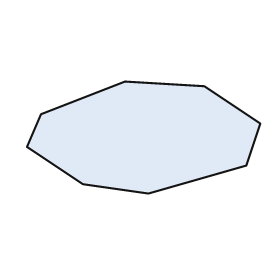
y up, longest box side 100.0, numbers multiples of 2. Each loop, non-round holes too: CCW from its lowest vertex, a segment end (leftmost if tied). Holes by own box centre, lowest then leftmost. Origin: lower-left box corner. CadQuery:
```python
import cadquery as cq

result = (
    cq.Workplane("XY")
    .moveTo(52.0, 0.0)
    .lineTo(94.0, 12.0)
    .lineTo(100.0, 30.0)
    .lineTo(76.0, 46.0)
    .lineTo(42.0, 48.0)
    .lineTo(6.0, 34.0)
    .lineTo(0.0, 20.0)
    .lineTo(24.0, 4.0)
    .close()
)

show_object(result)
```